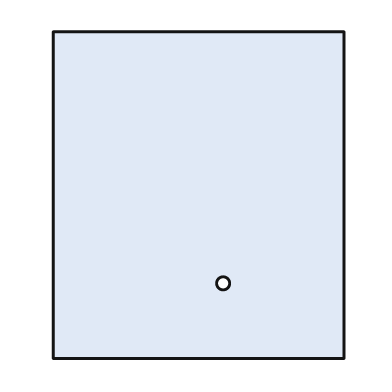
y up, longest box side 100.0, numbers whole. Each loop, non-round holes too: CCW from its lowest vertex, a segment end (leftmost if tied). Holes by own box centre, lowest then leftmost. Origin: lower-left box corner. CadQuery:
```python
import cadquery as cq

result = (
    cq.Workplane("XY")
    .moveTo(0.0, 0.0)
    .lineTo(89.0, 0.0)
    .lineTo(89.0, 100.0)
    .lineTo(0.0, 100.0)
    .close()
    .moveTo(52.0, 23.0)
    .circle(2.0)
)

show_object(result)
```